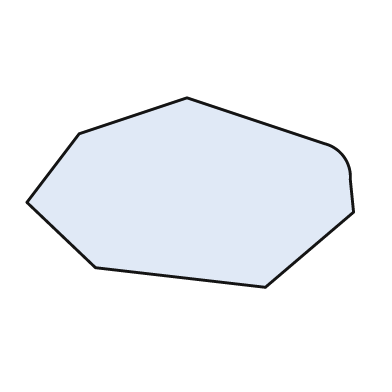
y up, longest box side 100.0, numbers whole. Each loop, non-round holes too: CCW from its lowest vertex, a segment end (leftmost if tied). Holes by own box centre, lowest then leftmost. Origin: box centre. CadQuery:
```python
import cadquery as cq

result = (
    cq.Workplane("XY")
    .moveTo(23.0, -29.0)
    .lineTo(50.0, -6.0)
    .lineTo(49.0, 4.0)
    .threePointArc((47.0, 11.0), (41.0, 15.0))
    .lineTo(-1.0, 29.0)
    .lineTo(-34.0, 18.0)
    .lineTo(-50.0, -3.0)
    .lineTo(-29.0, -23.0)
    .close()
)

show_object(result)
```